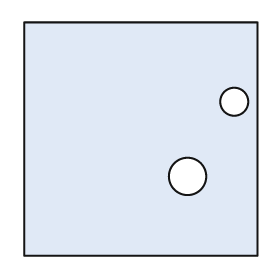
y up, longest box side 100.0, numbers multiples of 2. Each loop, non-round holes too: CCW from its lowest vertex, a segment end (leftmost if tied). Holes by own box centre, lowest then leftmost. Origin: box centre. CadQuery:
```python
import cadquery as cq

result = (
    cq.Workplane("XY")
    .moveTo(-50.0, -50.0)
    .lineTo(50.0, -50.0)
    .lineTo(50.0, 50.0)
    .lineTo(-50.0, 50.0)
    .close()
    .moveTo(20.0, -16.0)
    .circle(8.0)
    .moveTo(40.0, 16.0)
    .circle(6.0)
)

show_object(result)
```